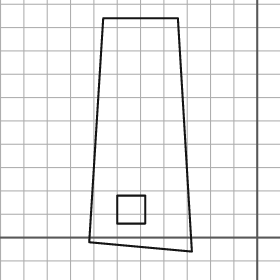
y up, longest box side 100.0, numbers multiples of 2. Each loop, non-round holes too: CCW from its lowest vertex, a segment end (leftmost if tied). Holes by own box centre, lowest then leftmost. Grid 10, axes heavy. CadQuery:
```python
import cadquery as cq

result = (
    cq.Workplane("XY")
    .moveTo(-28.0, -6.0)
    .lineTo(-34.0, 94.0)
    .lineTo(-66.0, 94.0)
    .lineTo(-72.0, -2.0)
    .close()
    .moveTo(-60.0, 6.0)
    .lineTo(-48.0, 6.0)
    .lineTo(-48.0, 18.0)
    .lineTo(-60.0, 18.0)
    .close()
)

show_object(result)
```